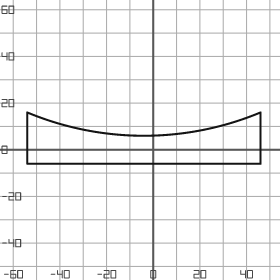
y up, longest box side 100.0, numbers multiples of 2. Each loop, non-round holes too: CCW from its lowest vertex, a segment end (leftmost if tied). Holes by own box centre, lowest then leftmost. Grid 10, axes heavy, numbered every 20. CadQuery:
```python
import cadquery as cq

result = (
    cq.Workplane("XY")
    .moveTo(-54.0, -6.0)
    .lineTo(46.0, -6.0)
    .lineTo(46.0, 16.0)
    .threePointArc((-4.0, 6.0), (-54.0, 16.0))
    .close()
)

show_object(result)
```